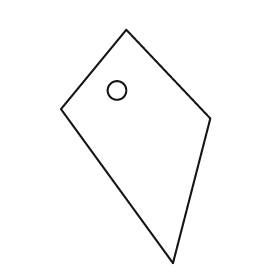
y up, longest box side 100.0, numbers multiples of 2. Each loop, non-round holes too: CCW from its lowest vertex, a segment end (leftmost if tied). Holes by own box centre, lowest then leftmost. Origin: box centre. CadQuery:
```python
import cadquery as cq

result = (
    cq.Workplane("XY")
    .moveTo(16.0, -50.0)
    .lineTo(32.0, 12.0)
    .lineTo(-4.0, 50.0)
    .lineTo(-32.0, 16.0)
    .close()
    .moveTo(-8.0, 24.0)
    .circle(4.0)
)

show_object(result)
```